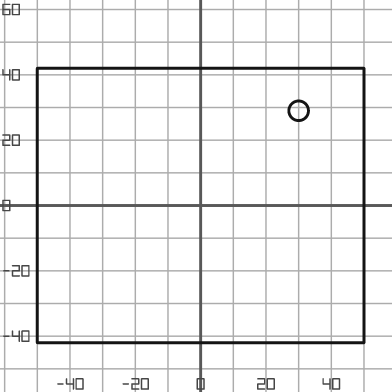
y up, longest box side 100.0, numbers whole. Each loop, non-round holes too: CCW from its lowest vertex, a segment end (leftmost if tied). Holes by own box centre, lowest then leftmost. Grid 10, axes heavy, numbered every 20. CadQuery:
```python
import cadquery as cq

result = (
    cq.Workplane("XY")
    .moveTo(-50.0, -42.0)
    .lineTo(50.0, -42.0)
    .lineTo(50.0, 42.0)
    .lineTo(-50.0, 42.0)
    .close()
    .moveTo(30.0, 29.0)
    .circle(3.0)
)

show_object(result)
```